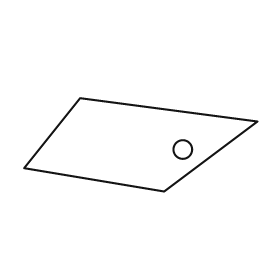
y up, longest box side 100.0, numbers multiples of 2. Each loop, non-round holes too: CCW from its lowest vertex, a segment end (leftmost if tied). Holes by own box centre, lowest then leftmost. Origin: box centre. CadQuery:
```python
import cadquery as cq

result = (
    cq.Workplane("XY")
    .moveTo(10.0, -20.0)
    .lineTo(50.0, 10.0)
    .lineTo(-26.0, 20.0)
    .lineTo(-50.0, -10.0)
    .close()
    .moveTo(18.0, -2.0)
    .circle(4.0)
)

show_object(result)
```